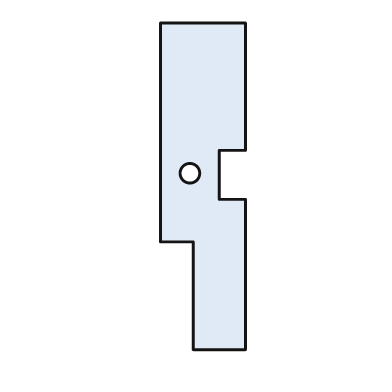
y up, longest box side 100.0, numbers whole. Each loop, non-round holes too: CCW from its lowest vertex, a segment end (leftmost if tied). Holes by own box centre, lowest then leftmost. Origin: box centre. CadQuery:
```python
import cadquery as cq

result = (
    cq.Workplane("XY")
    .moveTo(-3.0, -50.0)
    .lineTo(13.0, -50.0)
    .lineTo(13.0, -4.0)
    .lineTo(5.0, -4.0)
    .lineTo(5.0, 11.0)
    .lineTo(13.0, 11.0)
    .lineTo(13.0, 50.0)
    .lineTo(-13.0, 50.0)
    .lineTo(-13.0, -17.0)
    .lineTo(-3.0, -17.0)
    .close()
    .moveTo(-4.0, 4.0)
    .circle(3.0)
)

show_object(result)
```